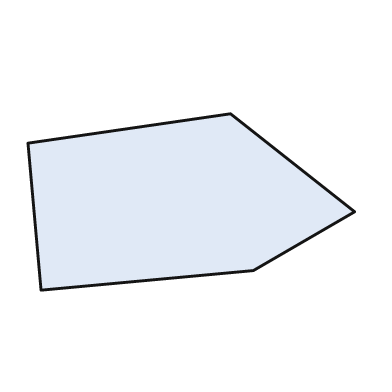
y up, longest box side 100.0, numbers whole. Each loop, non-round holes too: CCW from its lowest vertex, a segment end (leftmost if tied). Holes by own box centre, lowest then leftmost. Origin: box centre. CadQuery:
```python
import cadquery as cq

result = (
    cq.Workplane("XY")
    .moveTo(-46.0, -27.0)
    .lineTo(19.0, -21.0)
    .lineTo(50.0, -3.0)
    .lineTo(12.0, 27.0)
    .lineTo(-50.0, 18.0)
    .close()
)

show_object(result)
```